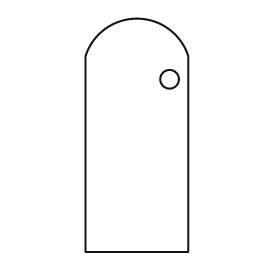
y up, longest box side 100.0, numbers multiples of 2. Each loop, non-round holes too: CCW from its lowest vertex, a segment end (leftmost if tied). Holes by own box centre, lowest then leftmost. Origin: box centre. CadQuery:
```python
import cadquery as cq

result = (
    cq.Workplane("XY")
    .moveTo(-22.0, -50.0)
    .lineTo(22.0, -50.0)
    .lineTo(22.0, 34.0)
    .threePointArc((0.0, 50.0), (-22.0, 34.0))
    .close()
    .moveTo(14.0, 24.0)
    .circle(4.0)
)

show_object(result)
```